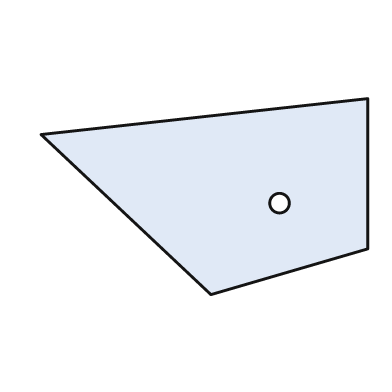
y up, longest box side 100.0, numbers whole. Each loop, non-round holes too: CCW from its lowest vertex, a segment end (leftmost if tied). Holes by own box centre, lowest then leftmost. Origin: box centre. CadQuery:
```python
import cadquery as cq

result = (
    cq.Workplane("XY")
    .moveTo(2.0, -30.0)
    .lineTo(50.0, -16.0)
    .lineTo(50.0, 30.0)
    .lineTo(-50.0, 19.0)
    .close()
    .moveTo(23.0, -2.0)
    .circle(3.0)
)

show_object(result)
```